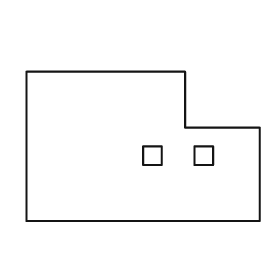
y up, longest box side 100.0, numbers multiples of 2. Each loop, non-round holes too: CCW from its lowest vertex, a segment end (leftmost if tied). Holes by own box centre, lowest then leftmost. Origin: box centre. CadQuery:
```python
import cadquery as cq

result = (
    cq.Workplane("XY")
    .moveTo(-50.0, -32.0)
    .lineTo(50.0, -32.0)
    .lineTo(50.0, 8.0)
    .lineTo(18.0, 8.0)
    .lineTo(18.0, 32.0)
    .lineTo(-50.0, 32.0)
    .close()
    .moveTo(0.0, -8.0)
    .lineTo(8.0, -8.0)
    .lineTo(8.0, 0.0)
    .lineTo(0.0, 0.0)
    .close()
    .moveTo(22.0, -8.0)
    .lineTo(30.0, -8.0)
    .lineTo(30.0, 0.0)
    .lineTo(22.0, 0.0)
    .close()
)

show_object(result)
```